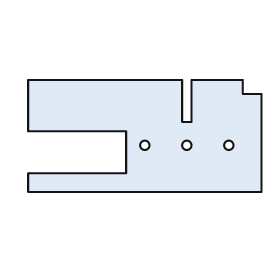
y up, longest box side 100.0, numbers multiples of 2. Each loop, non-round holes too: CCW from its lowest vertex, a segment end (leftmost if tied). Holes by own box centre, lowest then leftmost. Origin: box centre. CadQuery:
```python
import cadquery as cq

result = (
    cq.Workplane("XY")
    .moveTo(-50.0, -24.0)
    .lineTo(50.0, -24.0)
    .lineTo(50.0, 18.0)
    .lineTo(42.0, 18.0)
    .lineTo(42.0, 24.0)
    .lineTo(20.0, 24.0)
    .lineTo(20.0, 6.0)
    .lineTo(16.0, 6.0)
    .lineTo(16.0, 24.0)
    .lineTo(-50.0, 24.0)
    .lineTo(-50.0, 2.0)
    .lineTo(-8.0, 2.0)
    .lineTo(-8.0, -16.0)
    .lineTo(-50.0, -16.0)
    .close()
    .moveTo(0.0, -4.0)
    .circle(2.0)
    .moveTo(18.0, -4.0)
    .circle(2.0)
    .moveTo(36.0, -4.0)
    .circle(2.0)
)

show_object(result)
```